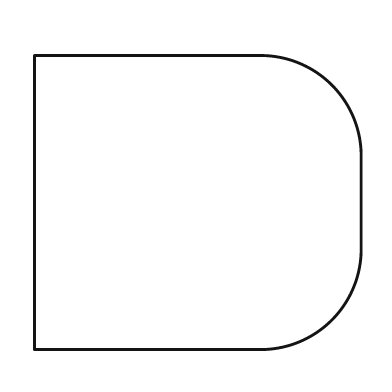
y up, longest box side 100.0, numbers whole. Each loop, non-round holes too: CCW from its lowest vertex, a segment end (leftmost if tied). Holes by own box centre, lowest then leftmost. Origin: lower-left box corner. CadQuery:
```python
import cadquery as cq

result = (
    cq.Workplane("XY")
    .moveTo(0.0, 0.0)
    .lineTo(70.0, 0.0)
    .threePointArc((91.0, 9.0), (100.0, 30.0))
    .lineTo(100.0, 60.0)
    .threePointArc((91.0, 81.0), (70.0, 90.0))
    .lineTo(0.0, 90.0)
    .close()
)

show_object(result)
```